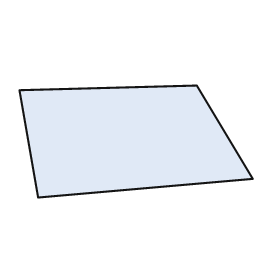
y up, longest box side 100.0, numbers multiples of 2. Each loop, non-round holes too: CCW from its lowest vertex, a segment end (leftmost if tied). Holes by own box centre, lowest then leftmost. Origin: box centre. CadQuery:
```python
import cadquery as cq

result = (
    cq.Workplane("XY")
    .moveTo(-42.0, -24.0)
    .lineTo(50.0, -16.0)
    .lineTo(26.0, 24.0)
    .lineTo(-50.0, 22.0)
    .close()
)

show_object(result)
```